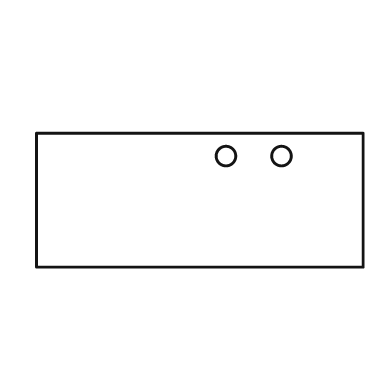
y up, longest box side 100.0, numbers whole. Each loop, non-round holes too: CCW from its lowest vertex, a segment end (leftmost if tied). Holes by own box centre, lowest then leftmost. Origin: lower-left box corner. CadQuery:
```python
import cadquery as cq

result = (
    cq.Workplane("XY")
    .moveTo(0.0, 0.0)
    .lineTo(100.0, 0.0)
    .lineTo(100.0, 41.0)
    .lineTo(0.0, 41.0)
    .close()
    .moveTo(58.0, 34.0)
    .circle(3.0)
    .moveTo(75.0, 34.0)
    .circle(3.0)
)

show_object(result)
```